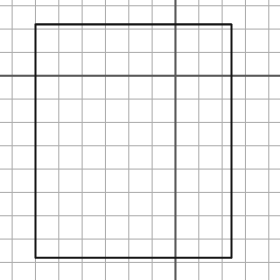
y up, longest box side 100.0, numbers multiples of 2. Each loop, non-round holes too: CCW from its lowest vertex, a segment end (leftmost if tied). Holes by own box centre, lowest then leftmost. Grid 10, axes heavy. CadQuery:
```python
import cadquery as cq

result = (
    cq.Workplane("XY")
    .moveTo(-60.0, -78.0)
    .lineTo(24.0, -78.0)
    .lineTo(24.0, 22.0)
    .lineTo(-60.0, 22.0)
    .close()
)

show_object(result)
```